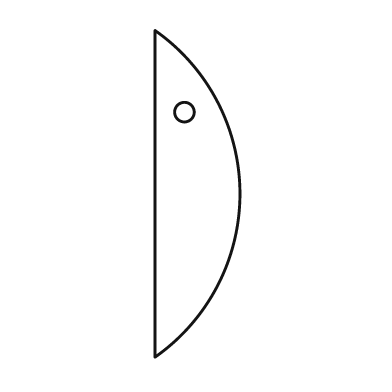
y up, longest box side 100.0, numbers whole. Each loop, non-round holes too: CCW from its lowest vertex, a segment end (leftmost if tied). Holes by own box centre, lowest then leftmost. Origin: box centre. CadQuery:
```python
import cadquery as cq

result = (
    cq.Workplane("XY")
    .moveTo(-13.0, -50.0)
    .threePointArc((13.0, 0.0), (-13.0, 50.0))
    .close()
    .moveTo(-4.0, 25.0)
    .circle(3.0)
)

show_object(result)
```